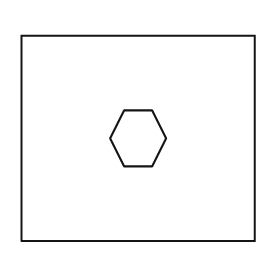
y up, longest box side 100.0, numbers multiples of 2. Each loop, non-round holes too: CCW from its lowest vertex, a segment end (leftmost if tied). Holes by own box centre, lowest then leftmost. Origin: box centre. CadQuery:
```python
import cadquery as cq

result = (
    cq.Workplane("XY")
    .moveTo(-50.0, -44.0)
    .lineTo(50.0, -44.0)
    .lineTo(50.0, 44.0)
    .lineTo(-50.0, 44.0)
    .close()
    .moveTo(-6.0, -12.0)
    .lineTo(6.0, -12.0)
    .lineTo(12.0, 0.0)
    .lineTo(6.0, 12.0)
    .lineTo(-6.0, 12.0)
    .lineTo(-12.0, 0.0)
    .close()
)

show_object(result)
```